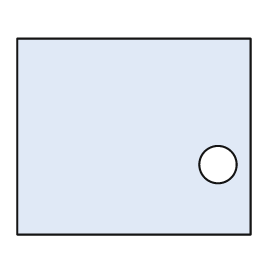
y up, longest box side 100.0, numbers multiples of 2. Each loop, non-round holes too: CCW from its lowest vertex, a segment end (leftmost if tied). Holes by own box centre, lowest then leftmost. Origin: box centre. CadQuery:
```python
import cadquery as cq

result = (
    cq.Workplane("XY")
    .moveTo(-50.0, -42.0)
    .lineTo(50.0, -42.0)
    .lineTo(50.0, 42.0)
    .lineTo(-50.0, 42.0)
    .close()
    .moveTo(36.0, -12.0)
    .circle(8.0)
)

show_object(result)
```